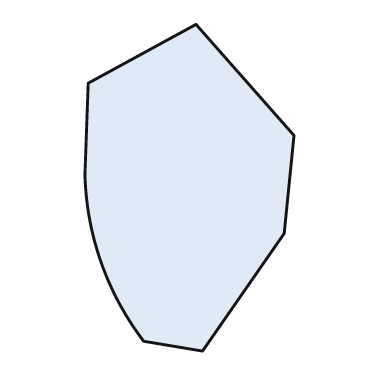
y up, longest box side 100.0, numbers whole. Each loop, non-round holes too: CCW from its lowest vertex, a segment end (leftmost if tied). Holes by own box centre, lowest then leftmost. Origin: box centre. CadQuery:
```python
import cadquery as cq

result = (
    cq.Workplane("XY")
    .moveTo(4.0, -50.0)
    .lineTo(29.0, -14.0)
    .lineTo(32.0, 16.0)
    .lineTo(2.0, 50.0)
    .lineTo(-31.0, 32.0)
    .lineTo(-32.0, 4.0)
    .threePointArc((-27.0, -23.0), (-14.0, -47.0))
    .close()
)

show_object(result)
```